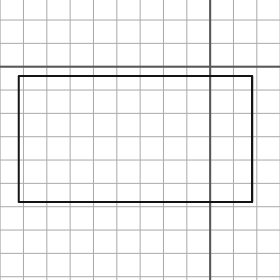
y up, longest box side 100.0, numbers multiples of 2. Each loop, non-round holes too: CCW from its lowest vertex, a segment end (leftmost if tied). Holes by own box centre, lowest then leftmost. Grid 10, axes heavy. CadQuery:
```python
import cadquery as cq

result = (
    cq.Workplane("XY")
    .moveTo(-82.0, -58.0)
    .lineTo(18.0, -58.0)
    .lineTo(18.0, -4.0)
    .lineTo(-82.0, -4.0)
    .close()
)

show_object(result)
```